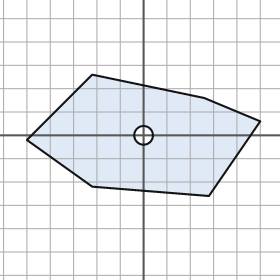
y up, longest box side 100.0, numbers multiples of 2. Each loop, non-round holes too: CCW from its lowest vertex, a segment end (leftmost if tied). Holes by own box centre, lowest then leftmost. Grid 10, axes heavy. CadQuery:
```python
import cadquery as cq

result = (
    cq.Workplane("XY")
    .moveTo(28.0, -26.0)
    .lineTo(50.0, 6.0)
    .lineTo(26.0, 16.0)
    .lineTo(-22.0, 26.0)
    .lineTo(-50.0, -2.0)
    .lineTo(-22.0, -22.0)
    .close()
    .moveTo(0.0, 0.0)
    .circle(4.0)
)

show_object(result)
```